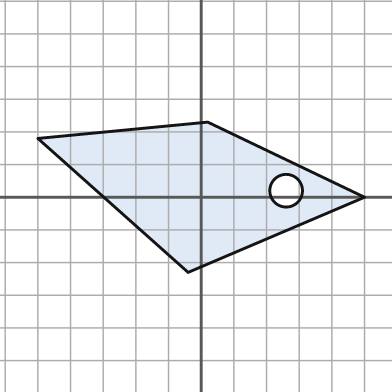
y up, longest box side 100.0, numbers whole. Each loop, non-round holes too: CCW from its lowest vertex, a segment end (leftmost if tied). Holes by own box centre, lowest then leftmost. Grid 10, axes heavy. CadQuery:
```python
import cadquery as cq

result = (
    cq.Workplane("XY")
    .moveTo(-4.0, -23.0)
    .lineTo(50.0, 0.0)
    .lineTo(2.0, 23.0)
    .lineTo(-50.0, 18.0)
    .close()
    .moveTo(26.0, 2.0)
    .circle(5.0)
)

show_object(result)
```